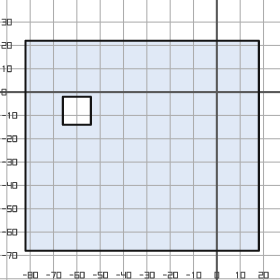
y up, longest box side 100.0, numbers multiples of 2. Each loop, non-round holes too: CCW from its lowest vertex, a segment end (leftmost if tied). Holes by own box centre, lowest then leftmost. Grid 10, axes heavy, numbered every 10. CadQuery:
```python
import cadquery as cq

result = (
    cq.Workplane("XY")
    .moveTo(-82.0, -68.0)
    .lineTo(18.0, -68.0)
    .lineTo(18.0, 22.0)
    .lineTo(-82.0, 22.0)
    .close()
    .moveTo(-66.0, -14.0)
    .lineTo(-54.0, -14.0)
    .lineTo(-54.0, -2.0)
    .lineTo(-66.0, -2.0)
    .close()
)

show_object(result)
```